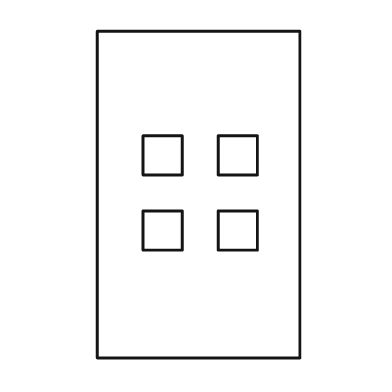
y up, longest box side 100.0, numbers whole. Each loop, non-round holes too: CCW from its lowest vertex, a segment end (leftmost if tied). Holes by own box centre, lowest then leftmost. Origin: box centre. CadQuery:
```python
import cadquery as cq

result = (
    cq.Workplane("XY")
    .moveTo(-31.0, -50.0)
    .lineTo(31.0, -50.0)
    .lineTo(31.0, 50.0)
    .lineTo(-31.0, 50.0)
    .close()
    .moveTo(-17.0, -17.0)
    .lineTo(-5.0, -17.0)
    .lineTo(-5.0, -5.0)
    .lineTo(-17.0, -5.0)
    .close()
    .moveTo(6.0, -17.0)
    .lineTo(18.0, -17.0)
    .lineTo(18.0, -5.0)
    .lineTo(6.0, -5.0)
    .close()
    .moveTo(-17.0, 6.0)
    .lineTo(-5.0, 6.0)
    .lineTo(-5.0, 18.0)
    .lineTo(-17.0, 18.0)
    .close()
    .moveTo(6.0, 6.0)
    .lineTo(18.0, 6.0)
    .lineTo(18.0, 18.0)
    .lineTo(6.0, 18.0)
    .close()
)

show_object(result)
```